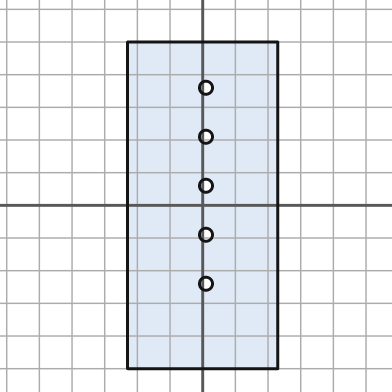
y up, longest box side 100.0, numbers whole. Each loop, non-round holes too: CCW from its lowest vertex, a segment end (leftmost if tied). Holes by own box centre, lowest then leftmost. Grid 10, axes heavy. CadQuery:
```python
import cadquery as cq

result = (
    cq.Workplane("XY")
    .moveTo(-23.0, -50.0)
    .lineTo(23.0, -50.0)
    .lineTo(23.0, 50.0)
    .lineTo(-23.0, 50.0)
    .close()
    .moveTo(1.0, -24.0)
    .circle(2.0)
    .moveTo(1.0, -9.0)
    .circle(2.0)
    .moveTo(1.0, 6.0)
    .circle(2.0)
    .moveTo(1.0, 21.0)
    .circle(2.0)
    .moveTo(1.0, 36.0)
    .circle(2.0)
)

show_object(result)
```